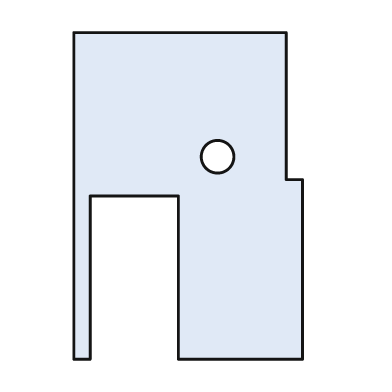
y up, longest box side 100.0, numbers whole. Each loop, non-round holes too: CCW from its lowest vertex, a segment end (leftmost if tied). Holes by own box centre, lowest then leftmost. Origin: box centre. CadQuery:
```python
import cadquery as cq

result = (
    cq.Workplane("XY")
    .moveTo(-35.0, -50.0)
    .lineTo(-30.0, -50.0)
    .lineTo(-30.0, 0.0)
    .lineTo(-3.0, 0.0)
    .lineTo(-3.0, -50.0)
    .lineTo(35.0, -50.0)
    .lineTo(35.0, 5.0)
    .lineTo(30.0, 5.0)
    .lineTo(30.0, 50.0)
    .lineTo(-35.0, 50.0)
    .close()
    .moveTo(9.0, 12.0)
    .circle(5.0)
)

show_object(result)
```